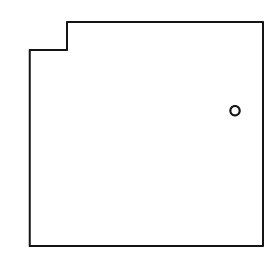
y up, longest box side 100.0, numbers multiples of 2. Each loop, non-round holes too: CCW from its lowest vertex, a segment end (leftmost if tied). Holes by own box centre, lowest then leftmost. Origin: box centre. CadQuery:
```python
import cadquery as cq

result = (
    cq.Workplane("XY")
    .moveTo(-50.0, -48.0)
    .lineTo(50.0, -48.0)
    .lineTo(50.0, 48.0)
    .lineTo(-34.0, 48.0)
    .lineTo(-34.0, 36.0)
    .lineTo(-50.0, 36.0)
    .close()
    .moveTo(38.0, 10.0)
    .circle(2.0)
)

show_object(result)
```